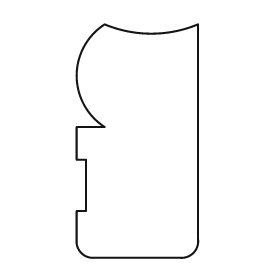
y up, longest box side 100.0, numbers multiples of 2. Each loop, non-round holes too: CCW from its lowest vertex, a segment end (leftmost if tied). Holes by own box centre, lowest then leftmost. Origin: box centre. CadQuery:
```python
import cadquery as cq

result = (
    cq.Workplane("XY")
    .moveTo(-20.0, -50.0)
    .lineTo(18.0, -50.0)
    .threePointArc((24.0, -48.0), (26.0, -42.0))
    .lineTo(26.0, 50.0)
    .threePointArc((6.0, 46.0), (-14.0, 50.0))
    .threePointArc((-26.0, 28.0), (-14.0, 6.0))
    .lineTo(-26.0, 6.0)
    .lineTo(-26.0, -8.0)
    .lineTo(-22.0, -8.0)
    .lineTo(-22.0, -30.0)
    .lineTo(-26.0, -30.0)
    .lineTo(-26.0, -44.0)
    .threePointArc((-24.0, -48.0), (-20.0, -50.0))
    .close()
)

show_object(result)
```